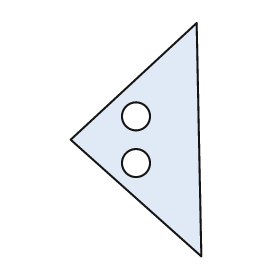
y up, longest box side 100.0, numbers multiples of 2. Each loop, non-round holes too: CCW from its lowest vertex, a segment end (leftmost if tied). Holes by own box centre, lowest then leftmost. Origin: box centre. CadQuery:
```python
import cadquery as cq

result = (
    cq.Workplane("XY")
    .moveTo(28.0, -50.0)
    .lineTo(26.0, 50.0)
    .lineTo(-28.0, 0.0)
    .close()
    .moveTo(0.0, -10.0)
    .circle(6.0)
    .moveTo(0.0, 10.0)
    .circle(6.0)
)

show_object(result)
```